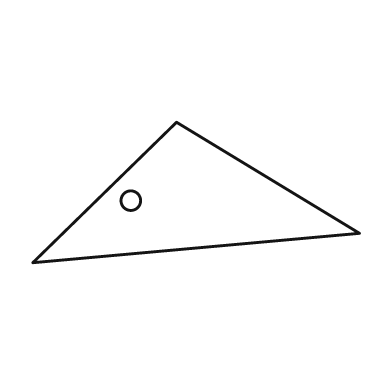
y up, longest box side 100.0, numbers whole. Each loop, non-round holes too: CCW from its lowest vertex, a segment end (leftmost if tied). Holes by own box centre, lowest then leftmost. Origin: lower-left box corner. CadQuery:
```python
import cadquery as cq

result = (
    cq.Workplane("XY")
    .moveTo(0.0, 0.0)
    .lineTo(100.0, 9.0)
    .lineTo(44.0, 43.0)
    .close()
    .moveTo(30.0, 19.0)
    .circle(3.0)
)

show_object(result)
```